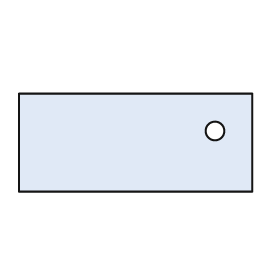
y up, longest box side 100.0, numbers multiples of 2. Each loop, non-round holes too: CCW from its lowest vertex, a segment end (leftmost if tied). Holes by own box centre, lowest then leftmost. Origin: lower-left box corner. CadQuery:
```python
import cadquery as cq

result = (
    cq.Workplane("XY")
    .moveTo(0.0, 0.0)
    .lineTo(100.0, 0.0)
    .lineTo(100.0, 42.0)
    .lineTo(0.0, 42.0)
    .close()
    .moveTo(84.0, 26.0)
    .circle(4.0)
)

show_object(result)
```